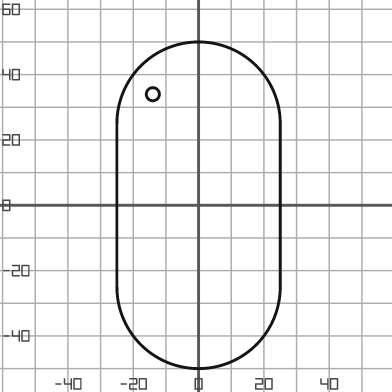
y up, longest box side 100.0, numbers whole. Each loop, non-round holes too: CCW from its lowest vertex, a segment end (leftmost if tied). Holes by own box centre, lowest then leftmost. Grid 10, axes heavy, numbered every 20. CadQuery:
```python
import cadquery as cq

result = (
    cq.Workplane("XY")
    .moveTo(-25.0, -25.0)
    .threePointArc((0.0, -50.0), (25.0, -25.0))
    .lineTo(25.0, 25.0)
    .threePointArc((0.0, 50.0), (-25.0, 25.0))
    .close()
    .moveTo(-14.0, 34.0)
    .circle(2.0)
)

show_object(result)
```